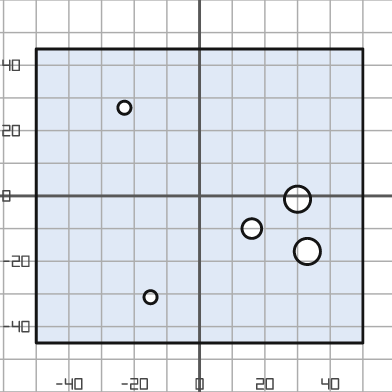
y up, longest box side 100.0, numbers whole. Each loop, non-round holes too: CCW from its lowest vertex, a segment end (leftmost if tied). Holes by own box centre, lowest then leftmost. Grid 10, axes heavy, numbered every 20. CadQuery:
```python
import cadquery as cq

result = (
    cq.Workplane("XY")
    .moveTo(-50.0, -45.0)
    .lineTo(50.0, -45.0)
    .lineTo(50.0, 45.0)
    .lineTo(-50.0, 45.0)
    .close()
    .moveTo(-15.0, -31.0)
    .circle(2.0)
    .moveTo(33.0, -17.0)
    .circle(4.0)
    .moveTo(16.0, -10.0)
    .circle(3.0)
    .moveTo(30.0, -1.0)
    .circle(4.0)
    .moveTo(-23.0, 27.0)
    .circle(2.0)
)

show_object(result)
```